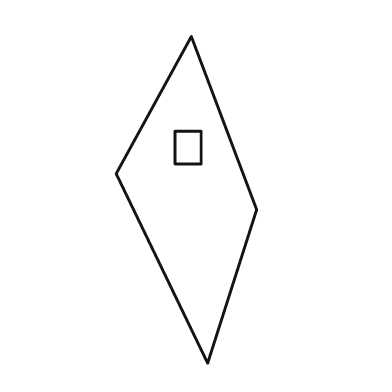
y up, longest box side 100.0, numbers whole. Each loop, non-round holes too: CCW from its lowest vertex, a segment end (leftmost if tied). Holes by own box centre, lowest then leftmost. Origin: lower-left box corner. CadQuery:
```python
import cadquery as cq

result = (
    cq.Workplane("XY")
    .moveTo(28.0, 0.0)
    .lineTo(43.0, 47.0)
    .lineTo(23.0, 100.0)
    .lineTo(0.0, 58.0)
    .close()
    .moveTo(18.0, 61.0)
    .lineTo(26.0, 61.0)
    .lineTo(26.0, 71.0)
    .lineTo(18.0, 71.0)
    .close()
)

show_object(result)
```